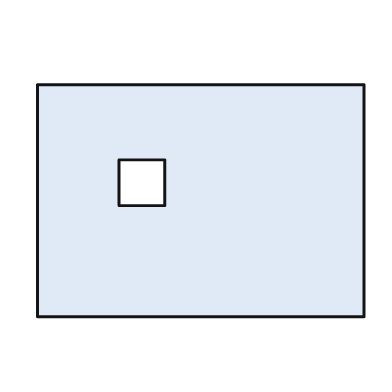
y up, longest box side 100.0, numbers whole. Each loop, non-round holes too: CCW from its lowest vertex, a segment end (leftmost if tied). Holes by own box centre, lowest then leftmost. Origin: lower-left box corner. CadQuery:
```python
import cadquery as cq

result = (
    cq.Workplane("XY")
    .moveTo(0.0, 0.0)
    .lineTo(100.0, 0.0)
    .lineTo(100.0, 71.0)
    .lineTo(0.0, 71.0)
    .close()
    .moveTo(25.0, 34.0)
    .lineTo(39.0, 34.0)
    .lineTo(39.0, 48.0)
    .lineTo(25.0, 48.0)
    .close()
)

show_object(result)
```